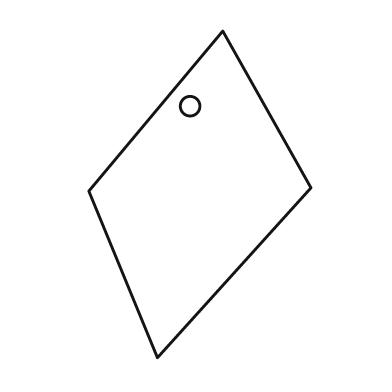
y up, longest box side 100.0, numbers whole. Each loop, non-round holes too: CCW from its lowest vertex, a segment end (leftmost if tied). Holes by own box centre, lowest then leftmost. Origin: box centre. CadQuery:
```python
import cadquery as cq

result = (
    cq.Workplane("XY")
    .moveTo(-13.0, -50.0)
    .lineTo(34.0, 2.0)
    .lineTo(7.0, 50.0)
    .lineTo(-34.0, 1.0)
    .close()
    .moveTo(-3.0, 27.0)
    .circle(3.0)
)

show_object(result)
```